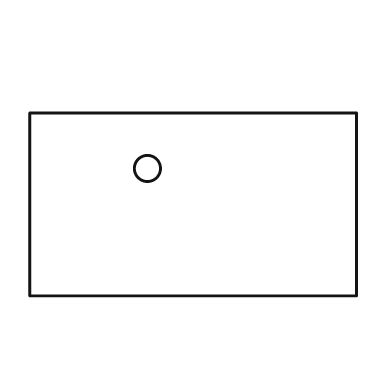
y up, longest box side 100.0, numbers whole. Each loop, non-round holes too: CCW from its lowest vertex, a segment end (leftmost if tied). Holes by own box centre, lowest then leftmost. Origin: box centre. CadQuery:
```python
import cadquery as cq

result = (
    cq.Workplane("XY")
    .moveTo(-50.0, -28.0)
    .lineTo(50.0, -28.0)
    .lineTo(50.0, 28.0)
    .lineTo(-50.0, 28.0)
    .close()
    .moveTo(-14.0, 11.0)
    .circle(4.0)
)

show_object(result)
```